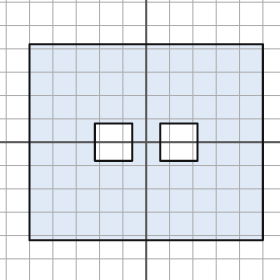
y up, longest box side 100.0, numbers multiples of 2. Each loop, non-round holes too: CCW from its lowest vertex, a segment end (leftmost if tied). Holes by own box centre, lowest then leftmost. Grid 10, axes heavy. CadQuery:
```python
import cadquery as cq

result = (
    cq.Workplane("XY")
    .moveTo(-50.0, -42.0)
    .lineTo(50.0, -42.0)
    .lineTo(50.0, 42.0)
    .lineTo(-50.0, 42.0)
    .close()
    .moveTo(-22.0, -8.0)
    .lineTo(-6.0, -8.0)
    .lineTo(-6.0, 8.0)
    .lineTo(-22.0, 8.0)
    .close()
    .moveTo(6.0, -8.0)
    .lineTo(22.0, -8.0)
    .lineTo(22.0, 8.0)
    .lineTo(6.0, 8.0)
    .close()
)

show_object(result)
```